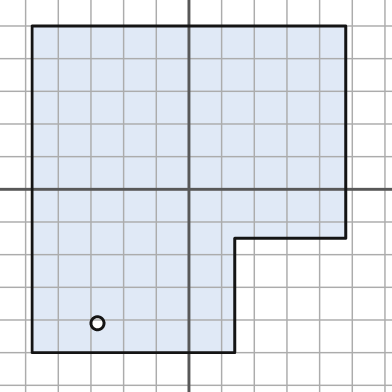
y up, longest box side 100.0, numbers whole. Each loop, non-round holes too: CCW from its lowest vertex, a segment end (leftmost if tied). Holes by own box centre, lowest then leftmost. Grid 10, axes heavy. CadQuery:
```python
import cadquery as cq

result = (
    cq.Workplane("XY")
    .moveTo(-48.0, -50.0)
    .lineTo(14.0, -50.0)
    .lineTo(14.0, -15.0)
    .lineTo(48.0, -15.0)
    .lineTo(48.0, 50.0)
    .lineTo(-48.0, 50.0)
    .close()
    .moveTo(-28.0, -41.0)
    .circle(2.0)
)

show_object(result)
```